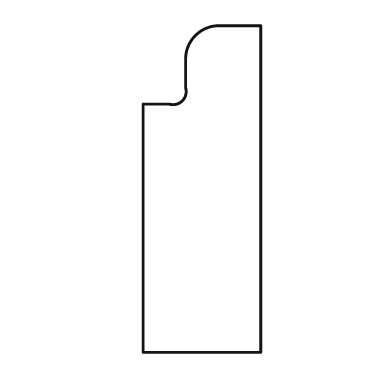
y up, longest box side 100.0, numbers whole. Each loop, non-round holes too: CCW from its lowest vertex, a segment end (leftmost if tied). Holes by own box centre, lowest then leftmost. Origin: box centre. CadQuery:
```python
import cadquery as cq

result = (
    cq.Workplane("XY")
    .moveTo(-18.0, -50.0)
    .lineTo(18.0, -50.0)
    .lineTo(18.0, 50.0)
    .lineTo(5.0, 50.0)
    .threePointArc((-2.0, 47.0), (-5.0, 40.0))
    .lineTo(-5.0, 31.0)
    .threePointArc((-6.0, 27.0), (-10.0, 26.0))
    .lineTo(-18.0, 26.0)
    .close()
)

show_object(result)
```